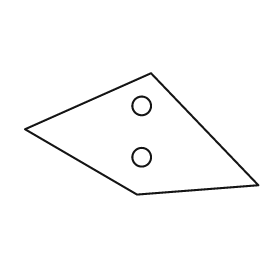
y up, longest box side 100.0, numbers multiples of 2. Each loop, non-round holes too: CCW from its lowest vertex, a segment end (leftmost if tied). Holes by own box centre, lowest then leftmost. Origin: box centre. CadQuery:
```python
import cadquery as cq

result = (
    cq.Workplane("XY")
    .moveTo(-2.0, -26.0)
    .lineTo(50.0, -22.0)
    .lineTo(4.0, 26.0)
    .lineTo(-50.0, 2.0)
    .close()
    .moveTo(0.0, -10.0)
    .circle(4.0)
    .moveTo(0.0, 12.0)
    .circle(4.0)
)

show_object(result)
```